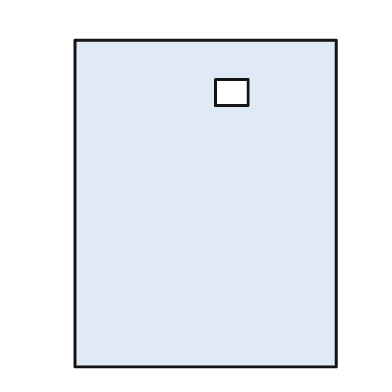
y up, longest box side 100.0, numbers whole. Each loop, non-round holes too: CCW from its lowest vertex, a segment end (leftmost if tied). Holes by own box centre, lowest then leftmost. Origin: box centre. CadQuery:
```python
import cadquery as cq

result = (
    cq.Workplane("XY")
    .moveTo(-40.0, -50.0)
    .lineTo(40.0, -50.0)
    .lineTo(40.0, 50.0)
    .lineTo(-40.0, 50.0)
    .close()
    .moveTo(3.0, 30.0)
    .lineTo(13.0, 30.0)
    .lineTo(13.0, 38.0)
    .lineTo(3.0, 38.0)
    .close()
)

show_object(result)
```